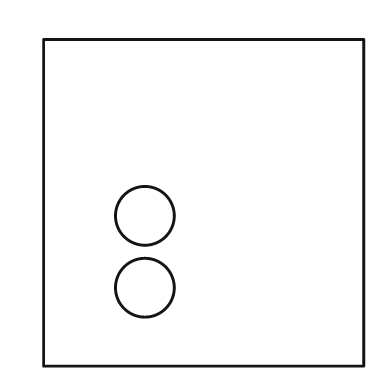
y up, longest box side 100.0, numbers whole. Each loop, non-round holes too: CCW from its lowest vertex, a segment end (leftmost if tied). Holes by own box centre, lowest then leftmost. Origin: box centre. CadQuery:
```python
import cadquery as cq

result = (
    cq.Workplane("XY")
    .moveTo(-49.0, -50.0)
    .lineTo(49.0, -50.0)
    .lineTo(49.0, 50.0)
    .lineTo(-49.0, 50.0)
    .close()
    .moveTo(-18.0, -26.0)
    .circle(9.0)
    .moveTo(-18.0, -4.0)
    .circle(9.0)
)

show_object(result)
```